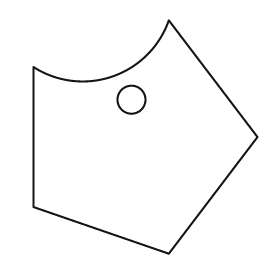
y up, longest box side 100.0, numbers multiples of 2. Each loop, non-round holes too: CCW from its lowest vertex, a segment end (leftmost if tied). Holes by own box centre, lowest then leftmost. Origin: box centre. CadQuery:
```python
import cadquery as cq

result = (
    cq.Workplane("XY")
    .moveTo(10.0, -50.0)
    .lineTo(48.0, 0.0)
    .lineTo(10.0, 50.0)
    .threePointArc((-14.0, 26.0), (-48.0, 30.0))
    .lineTo(-48.0, -30.0)
    .close()
    .moveTo(-6.0, 16.0)
    .circle(6.0)
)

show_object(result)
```